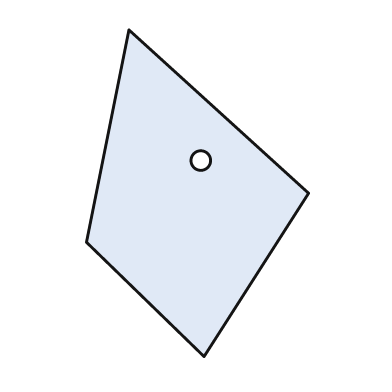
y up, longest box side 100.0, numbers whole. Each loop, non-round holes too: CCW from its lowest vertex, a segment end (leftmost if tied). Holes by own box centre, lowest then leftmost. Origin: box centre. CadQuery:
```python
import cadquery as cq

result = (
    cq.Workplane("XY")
    .moveTo(2.0, -50.0)
    .lineTo(34.0, 0.0)
    .lineTo(-21.0, 50.0)
    .lineTo(-34.0, -15.0)
    .close()
    .moveTo(1.0, 10.0)
    .circle(3.0)
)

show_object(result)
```